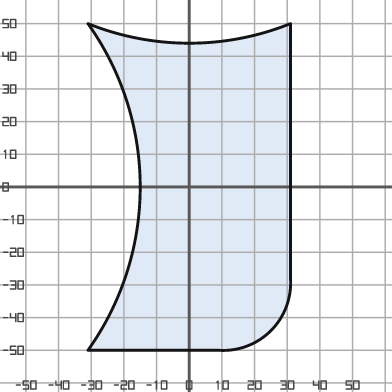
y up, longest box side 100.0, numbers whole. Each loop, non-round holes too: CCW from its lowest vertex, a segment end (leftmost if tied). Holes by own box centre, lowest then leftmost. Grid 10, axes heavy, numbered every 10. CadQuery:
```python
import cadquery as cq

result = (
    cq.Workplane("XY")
    .moveTo(-31.0, -50.0)
    .lineTo(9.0, -50.0)
    .threePointArc((25.0, -44.0), (31.0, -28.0))
    .lineTo(31.0, 50.0)
    .threePointArc((0.0, 44.0), (-31.0, 50.0))
    .threePointArc((-15.0, 0.0), (-31.0, -50.0))
    .close()
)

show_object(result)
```